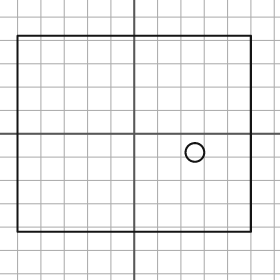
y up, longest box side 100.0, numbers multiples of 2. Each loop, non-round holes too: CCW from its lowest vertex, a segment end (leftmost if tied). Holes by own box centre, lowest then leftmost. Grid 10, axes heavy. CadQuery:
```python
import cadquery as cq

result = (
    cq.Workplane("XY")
    .moveTo(-50.0, -42.0)
    .lineTo(50.0, -42.0)
    .lineTo(50.0, 42.0)
    .lineTo(-50.0, 42.0)
    .close()
    .moveTo(26.0, -8.0)
    .circle(4.0)
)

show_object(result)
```